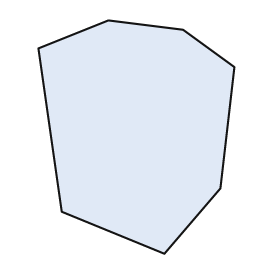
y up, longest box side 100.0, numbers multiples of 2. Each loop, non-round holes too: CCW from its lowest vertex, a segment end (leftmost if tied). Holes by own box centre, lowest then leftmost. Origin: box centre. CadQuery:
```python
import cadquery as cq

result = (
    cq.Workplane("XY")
    .moveTo(12.0, -50.0)
    .lineTo(36.0, -22.0)
    .lineTo(42.0, 30.0)
    .lineTo(20.0, 46.0)
    .lineTo(-12.0, 50.0)
    .lineTo(-42.0, 38.0)
    .lineTo(-32.0, -32.0)
    .close()
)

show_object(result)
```